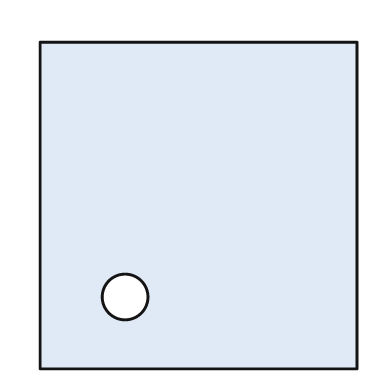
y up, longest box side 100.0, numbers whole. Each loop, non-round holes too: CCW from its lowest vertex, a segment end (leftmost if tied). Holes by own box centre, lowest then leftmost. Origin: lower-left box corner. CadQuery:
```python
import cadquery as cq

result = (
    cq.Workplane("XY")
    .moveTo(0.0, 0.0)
    .lineTo(97.0, 0.0)
    .lineTo(97.0, 100.0)
    .lineTo(0.0, 100.0)
    .close()
    .moveTo(26.0, 22.0)
    .circle(7.0)
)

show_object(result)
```